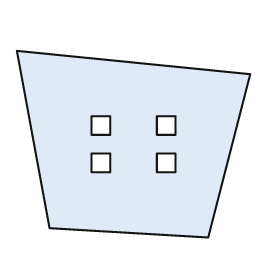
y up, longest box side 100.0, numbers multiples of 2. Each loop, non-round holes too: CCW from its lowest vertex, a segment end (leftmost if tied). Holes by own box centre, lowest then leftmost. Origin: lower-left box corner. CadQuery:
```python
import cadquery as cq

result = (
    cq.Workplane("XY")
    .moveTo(82.0, 0.0)
    .lineTo(100.0, 70.0)
    .lineTo(0.0, 80.0)
    .lineTo(14.0, 4.0)
    .close()
    .moveTo(32.0, 28.0)
    .lineTo(40.0, 28.0)
    .lineTo(40.0, 36.0)
    .lineTo(32.0, 36.0)
    .close()
    .moveTo(60.0, 28.0)
    .lineTo(68.0, 28.0)
    .lineTo(68.0, 36.0)
    .lineTo(60.0, 36.0)
    .close()
    .moveTo(32.0, 44.0)
    .lineTo(40.0, 44.0)
    .lineTo(40.0, 52.0)
    .lineTo(32.0, 52.0)
    .close()
    .moveTo(60.0, 44.0)
    .lineTo(68.0, 44.0)
    .lineTo(68.0, 52.0)
    .lineTo(60.0, 52.0)
    .close()
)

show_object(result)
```